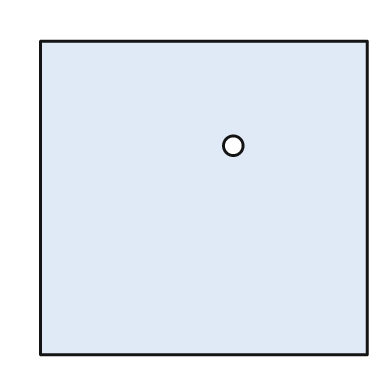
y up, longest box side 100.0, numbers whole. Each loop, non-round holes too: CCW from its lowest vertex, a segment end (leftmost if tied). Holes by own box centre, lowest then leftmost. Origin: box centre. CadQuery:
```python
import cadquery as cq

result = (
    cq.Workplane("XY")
    .moveTo(-50.0, -48.0)
    .lineTo(50.0, -48.0)
    .lineTo(50.0, 48.0)
    .lineTo(-50.0, 48.0)
    .close()
    .moveTo(9.0, 16.0)
    .circle(3.0)
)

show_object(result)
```